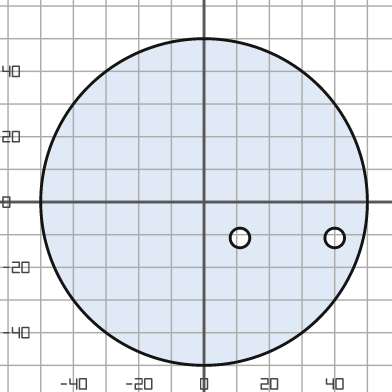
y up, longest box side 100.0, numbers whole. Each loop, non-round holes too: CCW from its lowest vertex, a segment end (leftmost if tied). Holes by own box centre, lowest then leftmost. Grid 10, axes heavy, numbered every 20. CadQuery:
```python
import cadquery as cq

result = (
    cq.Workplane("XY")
    .moveTo(0.0, 0.0)
    .circle(50.0)
    .moveTo(11.0, -11.0)
    .circle(3.0)
    .moveTo(40.0, -11.0)
    .circle(3.0)
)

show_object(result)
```